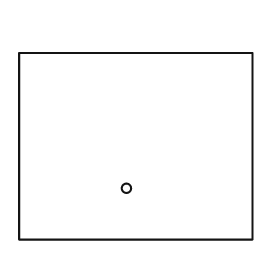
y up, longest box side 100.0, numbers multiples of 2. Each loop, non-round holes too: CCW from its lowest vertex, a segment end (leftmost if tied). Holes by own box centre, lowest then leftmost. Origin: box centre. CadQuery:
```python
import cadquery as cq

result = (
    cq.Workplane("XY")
    .moveTo(-50.0, -40.0)
    .lineTo(50.0, -40.0)
    .lineTo(50.0, 40.0)
    .lineTo(-50.0, 40.0)
    .close()
    .moveTo(-4.0, -18.0)
    .circle(2.0)
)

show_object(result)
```